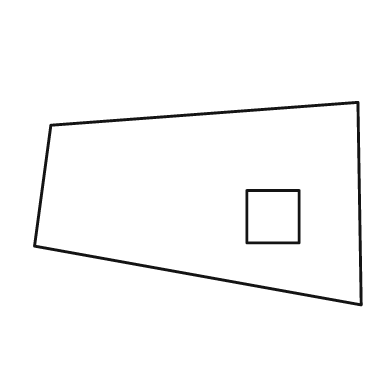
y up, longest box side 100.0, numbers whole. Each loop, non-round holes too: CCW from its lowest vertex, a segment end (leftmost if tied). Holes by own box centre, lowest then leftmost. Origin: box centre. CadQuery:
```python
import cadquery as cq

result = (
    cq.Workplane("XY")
    .moveTo(50.0, -31.0)
    .lineTo(49.0, 31.0)
    .lineTo(-45.0, 24.0)
    .lineTo(-50.0, -13.0)
    .close()
    .moveTo(15.0, -12.0)
    .lineTo(31.0, -12.0)
    .lineTo(31.0, 4.0)
    .lineTo(15.0, 4.0)
    .close()
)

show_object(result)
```